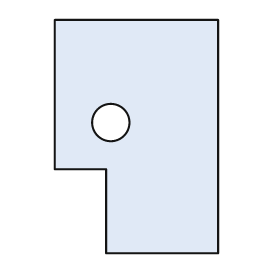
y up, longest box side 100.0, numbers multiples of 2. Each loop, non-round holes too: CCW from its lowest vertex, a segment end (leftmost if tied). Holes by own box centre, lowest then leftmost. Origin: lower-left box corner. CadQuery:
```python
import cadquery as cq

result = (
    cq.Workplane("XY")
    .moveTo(22.0, 0.0)
    .lineTo(70.0, 0.0)
    .lineTo(70.0, 100.0)
    .lineTo(0.0, 100.0)
    .lineTo(0.0, 36.0)
    .lineTo(22.0, 36.0)
    .close()
    .moveTo(24.0, 56.0)
    .circle(8.0)
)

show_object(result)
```